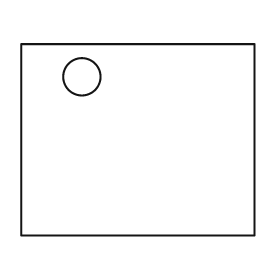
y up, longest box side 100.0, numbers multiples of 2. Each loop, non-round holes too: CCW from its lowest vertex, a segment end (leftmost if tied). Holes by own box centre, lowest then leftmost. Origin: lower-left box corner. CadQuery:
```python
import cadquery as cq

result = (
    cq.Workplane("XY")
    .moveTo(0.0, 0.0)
    .lineTo(100.0, 0.0)
    .lineTo(100.0, 82.0)
    .lineTo(0.0, 82.0)
    .close()
    .moveTo(26.0, 68.0)
    .circle(8.0)
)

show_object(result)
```